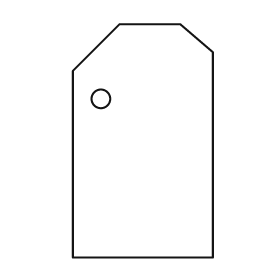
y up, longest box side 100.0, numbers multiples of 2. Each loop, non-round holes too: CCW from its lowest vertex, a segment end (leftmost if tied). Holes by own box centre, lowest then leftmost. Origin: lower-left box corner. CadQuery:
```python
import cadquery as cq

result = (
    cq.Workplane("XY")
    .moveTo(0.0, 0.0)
    .lineTo(60.0, 0.0)
    .lineTo(60.0, 88.0)
    .lineTo(46.0, 100.0)
    .lineTo(20.0, 100.0)
    .lineTo(0.0, 80.0)
    .close()
    .moveTo(12.0, 68.0)
    .circle(4.0)
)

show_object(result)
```